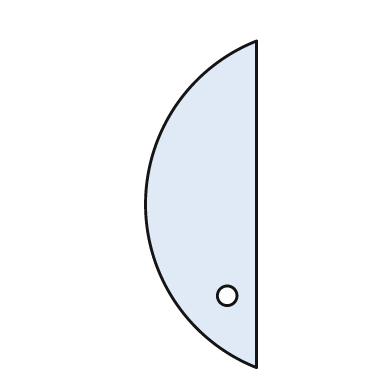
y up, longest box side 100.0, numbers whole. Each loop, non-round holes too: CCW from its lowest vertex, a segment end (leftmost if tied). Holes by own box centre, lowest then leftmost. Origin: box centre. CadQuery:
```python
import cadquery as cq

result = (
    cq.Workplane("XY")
    .moveTo(17.0, -50.0)
    .lineTo(17.0, 50.0)
    .threePointArc((-17.0, 0.0), (17.0, -50.0))
    .close()
    .moveTo(8.0, -28.0)
    .circle(3.0)
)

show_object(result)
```